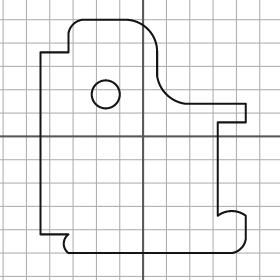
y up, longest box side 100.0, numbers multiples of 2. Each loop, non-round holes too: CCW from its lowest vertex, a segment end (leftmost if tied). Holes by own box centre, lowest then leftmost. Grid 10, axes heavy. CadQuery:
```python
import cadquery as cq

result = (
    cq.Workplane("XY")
    .moveTo(-32.0, -50.0)
    .lineTo(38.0, -50.0)
    .threePointArc((42.0, -48.0), (44.0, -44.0))
    .lineTo(44.0, -34.0)
    .threePointArc((38.0, -32.0), (32.0, -34.0))
    .lineTo(32.0, 6.0)
    .lineTo(44.0, 6.0)
    .lineTo(44.0, 14.0)
    .lineTo(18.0, 14.0)
    .threePointArc((10.0, 18.0), (6.0, 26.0))
    .lineTo(6.0, 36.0)
    .threePointArc((2.0, 46.0), (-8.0, 50.0))
    .lineTo(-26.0, 50.0)
    .threePointArc((-30.0, 48.0), (-32.0, 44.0))
    .lineTo(-32.0, 36.0)
    .lineTo(-44.0, 36.0)
    .lineTo(-44.0, -42.0)
    .lineTo(-32.0, -42.0)
    .threePointArc((-34.0, -46.0), (-32.0, -50.0))
    .close()
    .moveTo(-16.0, 18.0)
    .circle(6.0)
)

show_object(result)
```